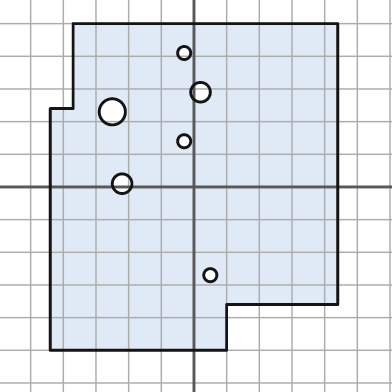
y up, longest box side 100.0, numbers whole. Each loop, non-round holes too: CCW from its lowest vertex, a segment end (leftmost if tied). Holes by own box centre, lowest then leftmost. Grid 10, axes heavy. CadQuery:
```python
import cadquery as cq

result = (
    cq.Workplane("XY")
    .moveTo(-44.0, -50.0)
    .lineTo(10.0, -50.0)
    .lineTo(10.0, -36.0)
    .lineTo(44.0, -36.0)
    .lineTo(44.0, 50.0)
    .lineTo(-37.0, 50.0)
    .lineTo(-37.0, 24.0)
    .lineTo(-44.0, 24.0)
    .close()
    .moveTo(5.0, -27.0)
    .circle(2.0)
    .moveTo(-22.0, 1.0)
    .circle(3.0)
    .moveTo(-3.0, 14.0)
    .circle(2.0)
    .moveTo(-25.0, 23.0)
    .circle(4.0)
    .moveTo(2.0, 29.0)
    .circle(3.0)
    .moveTo(-3.0, 41.0)
    .circle(2.0)
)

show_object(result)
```